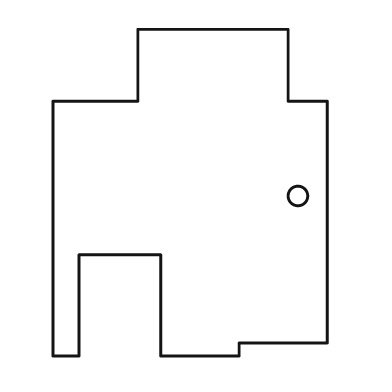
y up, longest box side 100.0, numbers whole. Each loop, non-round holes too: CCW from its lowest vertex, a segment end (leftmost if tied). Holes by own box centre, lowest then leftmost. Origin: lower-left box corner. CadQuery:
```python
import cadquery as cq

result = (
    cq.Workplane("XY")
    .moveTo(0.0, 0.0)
    .lineTo(8.0, 0.0)
    .lineTo(8.0, 31.0)
    .lineTo(33.0, 31.0)
    .lineTo(33.0, 0.0)
    .lineTo(57.0, 0.0)
    .lineTo(57.0, 4.0)
    .lineTo(84.0, 4.0)
    .lineTo(84.0, 78.0)
    .lineTo(72.0, 78.0)
    .lineTo(72.0, 100.0)
    .lineTo(26.0, 100.0)
    .lineTo(26.0, 78.0)
    .lineTo(0.0, 78.0)
    .close()
    .moveTo(75.0, 49.0)
    .circle(3.0)
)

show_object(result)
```